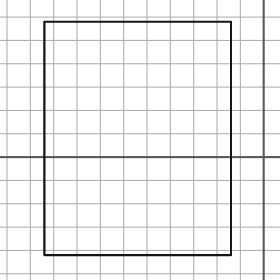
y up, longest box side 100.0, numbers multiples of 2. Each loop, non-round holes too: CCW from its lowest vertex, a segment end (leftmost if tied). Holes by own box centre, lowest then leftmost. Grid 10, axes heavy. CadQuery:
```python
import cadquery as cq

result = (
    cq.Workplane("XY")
    .moveTo(-94.0, -42.0)
    .lineTo(-14.0, -42.0)
    .lineTo(-14.0, 58.0)
    .lineTo(-94.0, 58.0)
    .close()
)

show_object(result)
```